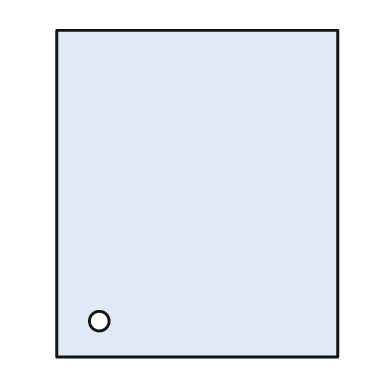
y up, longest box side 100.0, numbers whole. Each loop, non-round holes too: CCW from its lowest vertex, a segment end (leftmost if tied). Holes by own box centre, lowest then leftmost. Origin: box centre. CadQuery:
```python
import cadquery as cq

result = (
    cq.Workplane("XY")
    .moveTo(-43.0, -50.0)
    .lineTo(43.0, -50.0)
    .lineTo(43.0, 50.0)
    .lineTo(-43.0, 50.0)
    .close()
    .moveTo(-30.0, -39.0)
    .circle(3.0)
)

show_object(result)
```